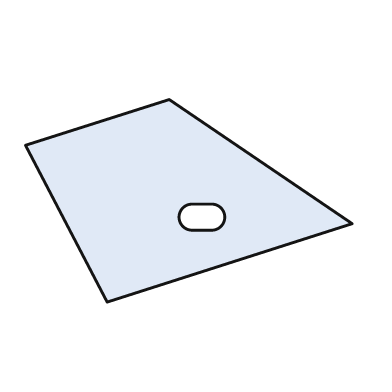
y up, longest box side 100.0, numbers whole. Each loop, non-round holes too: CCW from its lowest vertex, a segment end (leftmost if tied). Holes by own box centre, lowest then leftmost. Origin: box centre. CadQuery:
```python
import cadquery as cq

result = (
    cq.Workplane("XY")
    .moveTo(-25.0, -31.0)
    .lineTo(50.0, -7.0)
    .lineTo(-6.0, 31.0)
    .lineTo(-50.0, 17.0)
    .close()
    .moveTo(1.0, -9.0)
    .lineTo(7.0, -9.0)
    .threePointArc((11.0, -5.0), (7.0, -1.0))
    .lineTo(1.0, -1.0)
    .threePointArc((-3.0, -5.0), (1.0, -9.0))
    .close()
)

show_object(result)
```